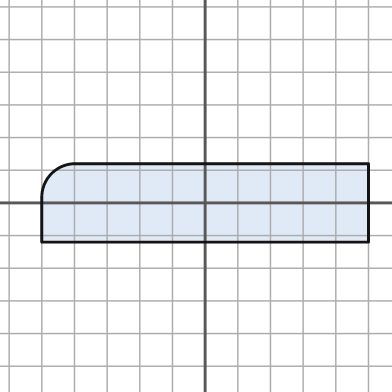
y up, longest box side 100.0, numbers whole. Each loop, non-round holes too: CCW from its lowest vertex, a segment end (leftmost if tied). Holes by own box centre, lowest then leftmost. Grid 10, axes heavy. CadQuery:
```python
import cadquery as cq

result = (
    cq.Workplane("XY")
    .moveTo(-50.0, -12.0)
    .lineTo(50.0, -12.0)
    .lineTo(50.0, 12.0)
    .lineTo(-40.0, 12.0)
    .threePointArc((-47.0, 9.0), (-50.0, 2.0))
    .close()
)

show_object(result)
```